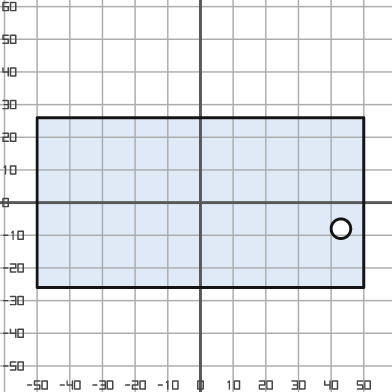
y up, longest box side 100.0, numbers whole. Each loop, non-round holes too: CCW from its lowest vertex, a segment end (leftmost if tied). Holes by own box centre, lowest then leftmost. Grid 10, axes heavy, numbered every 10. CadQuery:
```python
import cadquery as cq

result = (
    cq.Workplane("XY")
    .moveTo(-50.0, -26.0)
    .lineTo(50.0, -26.0)
    .lineTo(50.0, 26.0)
    .lineTo(-50.0, 26.0)
    .close()
    .moveTo(43.0, -8.0)
    .circle(3.0)
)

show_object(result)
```